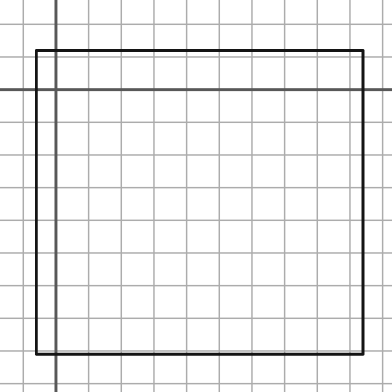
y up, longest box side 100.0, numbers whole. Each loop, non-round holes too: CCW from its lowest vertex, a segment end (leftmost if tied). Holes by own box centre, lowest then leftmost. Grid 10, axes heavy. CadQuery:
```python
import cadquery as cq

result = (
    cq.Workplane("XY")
    .moveTo(-6.0, -81.0)
    .lineTo(94.0, -81.0)
    .lineTo(94.0, 12.0)
    .lineTo(-6.0, 12.0)
    .close()
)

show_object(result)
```